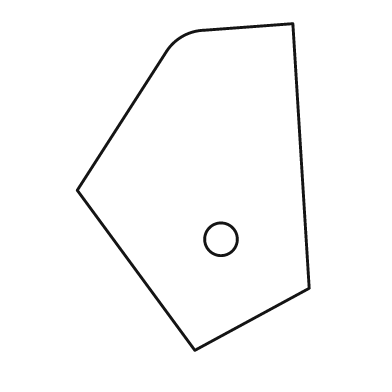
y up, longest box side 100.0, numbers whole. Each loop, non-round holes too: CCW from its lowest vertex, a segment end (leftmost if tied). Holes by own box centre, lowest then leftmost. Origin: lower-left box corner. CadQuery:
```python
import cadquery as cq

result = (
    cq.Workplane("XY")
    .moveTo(36.0, 0.0)
    .lineTo(71.0, 19.0)
    .lineTo(66.0, 100.0)
    .lineTo(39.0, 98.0)
    .threePointArc((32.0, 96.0), (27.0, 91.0))
    .lineTo(0.0, 49.0)
    .close()
    .moveTo(44.0, 34.0)
    .circle(5.0)
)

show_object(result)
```